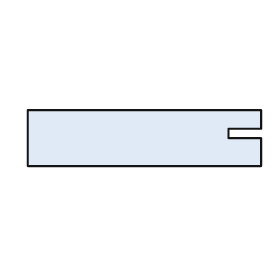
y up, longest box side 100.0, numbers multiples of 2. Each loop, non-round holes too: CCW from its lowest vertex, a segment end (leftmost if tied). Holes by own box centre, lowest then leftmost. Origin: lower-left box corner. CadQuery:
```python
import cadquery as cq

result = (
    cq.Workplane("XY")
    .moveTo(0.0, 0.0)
    .lineTo(100.0, 0.0)
    .lineTo(100.0, 12.0)
    .lineTo(86.0, 12.0)
    .lineTo(86.0, 16.0)
    .lineTo(100.0, 16.0)
    .lineTo(100.0, 24.0)
    .lineTo(0.0, 24.0)
    .close()
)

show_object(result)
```